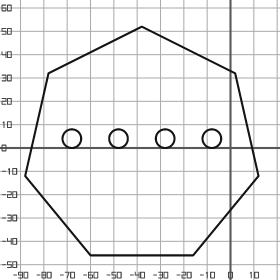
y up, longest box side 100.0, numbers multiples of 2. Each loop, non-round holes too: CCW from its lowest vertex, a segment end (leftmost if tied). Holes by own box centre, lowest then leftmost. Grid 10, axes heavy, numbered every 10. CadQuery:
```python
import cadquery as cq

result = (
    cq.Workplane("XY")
    .moveTo(-60.0, -46.0)
    .lineTo(-16.0, -46.0)
    .lineTo(12.0, -12.0)
    .lineTo(2.0, 32.0)
    .lineTo(-38.0, 52.0)
    .lineTo(-78.0, 32.0)
    .lineTo(-88.0, -12.0)
    .close()
    .moveTo(-68.0, 4.0)
    .circle(4.0)
    .moveTo(-48.0, 4.0)
    .circle(4.0)
    .moveTo(-28.0, 4.0)
    .circle(4.0)
    .moveTo(-8.0, 4.0)
    .circle(4.0)
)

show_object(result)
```